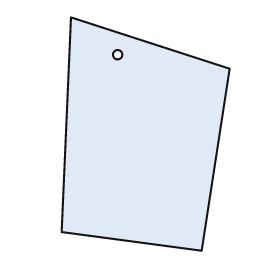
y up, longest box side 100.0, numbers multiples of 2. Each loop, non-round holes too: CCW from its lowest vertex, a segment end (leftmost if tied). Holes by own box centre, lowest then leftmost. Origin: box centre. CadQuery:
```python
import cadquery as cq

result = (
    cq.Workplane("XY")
    .moveTo(24.0, -50.0)
    .lineTo(36.0, 28.0)
    .lineTo(-32.0, 50.0)
    .lineTo(-36.0, -42.0)
    .close()
    .moveTo(-12.0, 34.0)
    .circle(2.0)
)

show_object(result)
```